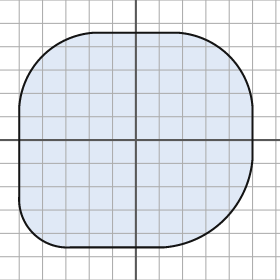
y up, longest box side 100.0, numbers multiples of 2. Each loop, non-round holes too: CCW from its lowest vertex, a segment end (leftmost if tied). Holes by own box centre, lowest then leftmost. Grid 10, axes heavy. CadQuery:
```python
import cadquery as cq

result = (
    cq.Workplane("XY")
    .moveTo(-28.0, -46.0)
    .lineTo(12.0, -46.0)
    .threePointArc((38.0, -34.0), (50.0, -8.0))
    .lineTo(50.0, 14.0)
    .threePointArc((40.0, 36.0), (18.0, 46.0))
    .lineTo(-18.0, 46.0)
    .threePointArc((-40.0, 36.0), (-50.0, 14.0))
    .lineTo(-50.0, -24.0)
    .threePointArc((-44.0, -40.0), (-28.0, -46.0))
    .close()
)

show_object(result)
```